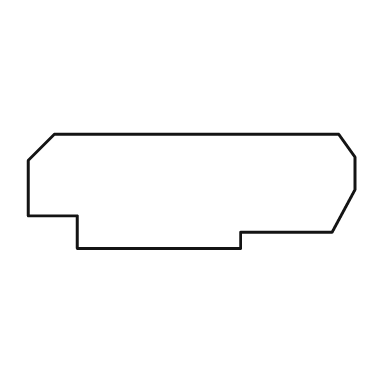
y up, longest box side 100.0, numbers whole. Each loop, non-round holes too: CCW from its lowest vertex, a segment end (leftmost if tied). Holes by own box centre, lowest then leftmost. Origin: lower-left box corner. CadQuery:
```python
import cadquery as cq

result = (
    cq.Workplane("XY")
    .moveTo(15.0, 0.0)
    .lineTo(65.0, 0.0)
    .lineTo(65.0, 5.0)
    .lineTo(93.0, 5.0)
    .lineTo(100.0, 18.0)
    .lineTo(100.0, 28.0)
    .lineTo(95.0, 35.0)
    .lineTo(8.0, 35.0)
    .lineTo(0.0, 27.0)
    .lineTo(0.0, 10.0)
    .lineTo(15.0, 10.0)
    .close()
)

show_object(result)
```